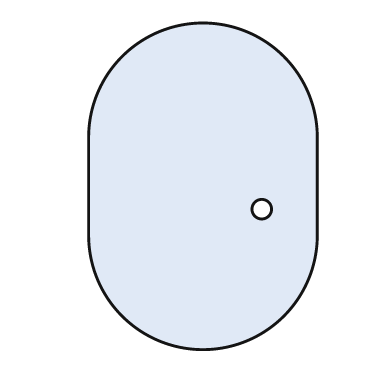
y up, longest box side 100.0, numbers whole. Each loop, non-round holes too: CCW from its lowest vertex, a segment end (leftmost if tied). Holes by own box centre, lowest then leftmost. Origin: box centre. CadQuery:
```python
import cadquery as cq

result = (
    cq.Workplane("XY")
    .moveTo(-35.0, -15.0)
    .threePointArc((0.0, -50.0), (35.0, -15.0))
    .lineTo(35.0, 15.0)
    .threePointArc((0.0, 50.0), (-35.0, 15.0))
    .close()
    .moveTo(18.0, -7.0)
    .circle(3.0)
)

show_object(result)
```